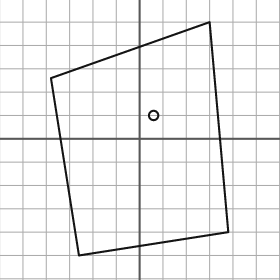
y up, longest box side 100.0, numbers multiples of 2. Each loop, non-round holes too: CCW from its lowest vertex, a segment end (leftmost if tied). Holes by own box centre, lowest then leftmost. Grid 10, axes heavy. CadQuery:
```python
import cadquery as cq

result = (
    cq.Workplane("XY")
    .moveTo(-26.0, -50.0)
    .lineTo(38.0, -40.0)
    .lineTo(30.0, 50.0)
    .lineTo(-38.0, 26.0)
    .close()
    .moveTo(6.0, 10.0)
    .circle(2.0)
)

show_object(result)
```